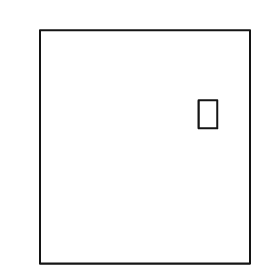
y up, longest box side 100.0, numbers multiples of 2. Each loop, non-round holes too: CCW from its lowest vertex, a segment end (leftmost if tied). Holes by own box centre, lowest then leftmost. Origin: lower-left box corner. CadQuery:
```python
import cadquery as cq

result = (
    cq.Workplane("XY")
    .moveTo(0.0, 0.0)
    .lineTo(90.0, 0.0)
    .lineTo(90.0, 100.0)
    .lineTo(0.0, 100.0)
    .close()
    .moveTo(68.0, 58.0)
    .lineTo(76.0, 58.0)
    .lineTo(76.0, 70.0)
    .lineTo(68.0, 70.0)
    .close()
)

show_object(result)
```